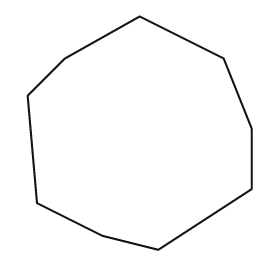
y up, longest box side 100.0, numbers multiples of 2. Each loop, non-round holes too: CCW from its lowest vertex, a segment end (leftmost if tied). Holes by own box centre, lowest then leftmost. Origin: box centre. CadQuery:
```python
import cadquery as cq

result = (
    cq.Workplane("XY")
    .moveTo(8.0, -50.0)
    .lineTo(48.0, -24.0)
    .lineTo(48.0, 2.0)
    .lineTo(36.0, 32.0)
    .lineTo(0.0, 50.0)
    .lineTo(-32.0, 32.0)
    .lineTo(-48.0, 16.0)
    .lineTo(-44.0, -30.0)
    .lineTo(-16.0, -44.0)
    .close()
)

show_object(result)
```